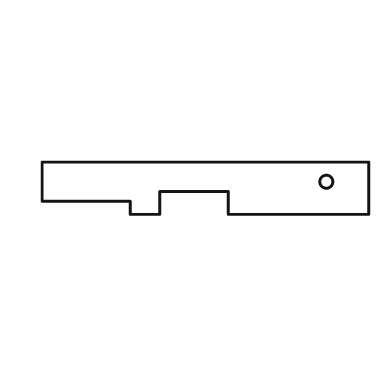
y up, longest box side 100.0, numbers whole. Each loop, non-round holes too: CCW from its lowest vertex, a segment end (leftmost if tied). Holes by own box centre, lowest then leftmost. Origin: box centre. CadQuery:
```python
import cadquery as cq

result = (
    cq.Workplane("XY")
    .moveTo(-23.0, -8.0)
    .lineTo(-14.0, -8.0)
    .lineTo(-14.0, -1.0)
    .lineTo(7.0, -1.0)
    .lineTo(7.0, -8.0)
    .lineTo(50.0, -8.0)
    .lineTo(50.0, 8.0)
    .lineTo(-50.0, 8.0)
    .lineTo(-50.0, -4.0)
    .lineTo(-23.0, -4.0)
    .close()
    .moveTo(37.0, 2.0)
    .circle(2.0)
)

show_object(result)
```